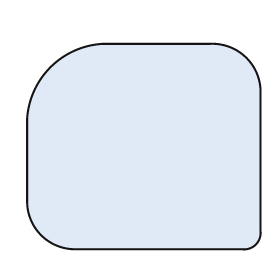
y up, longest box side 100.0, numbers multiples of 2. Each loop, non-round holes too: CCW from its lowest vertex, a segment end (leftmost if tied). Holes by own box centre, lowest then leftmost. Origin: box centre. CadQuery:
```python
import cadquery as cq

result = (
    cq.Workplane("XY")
    .moveTo(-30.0, -44.0)
    .lineTo(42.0, -44.0)
    .threePointArc((48.0, -42.0), (50.0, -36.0))
    .lineTo(50.0, 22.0)
    .threePointArc((44.0, 38.0), (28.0, 44.0))
    .lineTo(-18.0, 44.0)
    .threePointArc((-40.0, 34.0), (-50.0, 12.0))
    .lineTo(-50.0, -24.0)
    .threePointArc((-44.0, -38.0), (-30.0, -44.0))
    .close()
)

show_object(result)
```